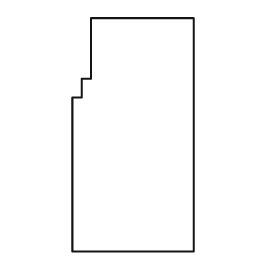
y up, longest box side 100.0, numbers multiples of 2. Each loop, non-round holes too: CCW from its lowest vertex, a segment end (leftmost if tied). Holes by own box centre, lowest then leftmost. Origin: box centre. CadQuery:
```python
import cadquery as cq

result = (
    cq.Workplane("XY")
    .moveTo(-26.0, -50.0)
    .lineTo(26.0, -50.0)
    .lineTo(26.0, 50.0)
    .lineTo(-18.0, 50.0)
    .lineTo(-18.0, 24.0)
    .lineTo(-22.0, 24.0)
    .lineTo(-22.0, 16.0)
    .lineTo(-26.0, 16.0)
    .close()
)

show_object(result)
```